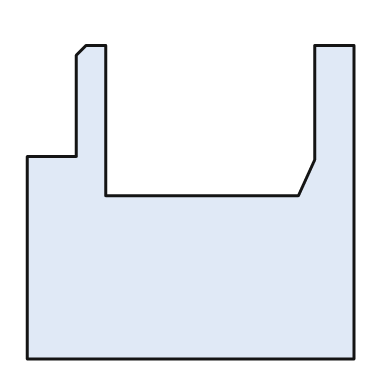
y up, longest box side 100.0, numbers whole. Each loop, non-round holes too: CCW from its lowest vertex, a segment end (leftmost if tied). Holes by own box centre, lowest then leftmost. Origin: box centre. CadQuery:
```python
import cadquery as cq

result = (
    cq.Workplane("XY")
    .moveTo(-50.0, -48.0)
    .lineTo(50.0, -48.0)
    .lineTo(50.0, 48.0)
    .lineTo(38.0, 48.0)
    .lineTo(38.0, 13.0)
    .lineTo(33.0, 2.0)
    .lineTo(-26.0, 2.0)
    .lineTo(-26.0, 48.0)
    .lineTo(-32.0, 48.0)
    .lineTo(-35.0, 45.0)
    .lineTo(-35.0, 14.0)
    .lineTo(-50.0, 14.0)
    .close()
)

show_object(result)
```